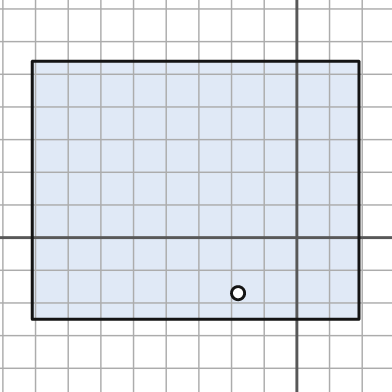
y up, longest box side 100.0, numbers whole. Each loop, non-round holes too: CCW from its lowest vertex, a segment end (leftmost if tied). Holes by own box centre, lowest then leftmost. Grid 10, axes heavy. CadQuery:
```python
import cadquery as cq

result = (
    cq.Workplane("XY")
    .moveTo(-81.0, -25.0)
    .lineTo(19.0, -25.0)
    .lineTo(19.0, 54.0)
    .lineTo(-81.0, 54.0)
    .close()
    .moveTo(-18.0, -17.0)
    .circle(2.0)
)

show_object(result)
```